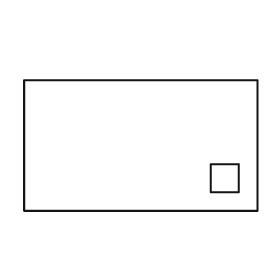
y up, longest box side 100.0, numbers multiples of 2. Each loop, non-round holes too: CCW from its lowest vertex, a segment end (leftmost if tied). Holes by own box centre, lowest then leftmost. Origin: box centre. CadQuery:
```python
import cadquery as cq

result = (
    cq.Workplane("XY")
    .moveTo(-50.0, -28.0)
    .lineTo(50.0, -28.0)
    .lineTo(50.0, 28.0)
    .lineTo(-50.0, 28.0)
    .close()
    .moveTo(30.0, -20.0)
    .lineTo(42.0, -20.0)
    .lineTo(42.0, -8.0)
    .lineTo(30.0, -8.0)
    .close()
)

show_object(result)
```